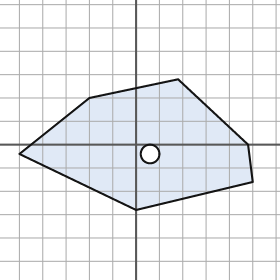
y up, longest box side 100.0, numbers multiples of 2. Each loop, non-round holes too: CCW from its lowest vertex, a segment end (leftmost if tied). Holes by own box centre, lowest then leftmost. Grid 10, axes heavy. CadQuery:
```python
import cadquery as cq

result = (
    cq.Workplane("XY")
    .moveTo(0.0, -28.0)
    .lineTo(50.0, -16.0)
    .lineTo(48.0, 0.0)
    .lineTo(18.0, 28.0)
    .lineTo(-20.0, 20.0)
    .lineTo(-50.0, -4.0)
    .close()
    .moveTo(6.0, -4.0)
    .circle(4.0)
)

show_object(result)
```